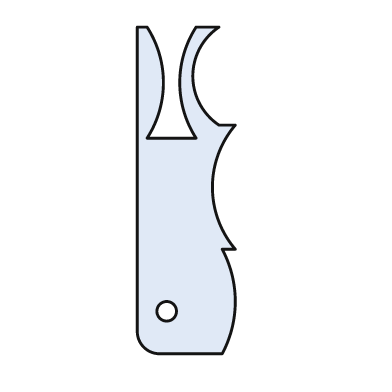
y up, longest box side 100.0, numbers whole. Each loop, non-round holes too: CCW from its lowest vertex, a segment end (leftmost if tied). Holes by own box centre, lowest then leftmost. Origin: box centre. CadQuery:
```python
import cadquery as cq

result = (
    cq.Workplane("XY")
    .moveTo(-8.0, -50.0)
    .lineTo(11.0, -50.0)
    .threePointArc((15.0, -34.0), (11.0, -18.0))
    .lineTo(15.0, -18.0)
    .threePointArc((8.0, 1.0), (15.0, 20.0))
    .lineTo(10.0, 20.0)
    .threePointArc((2.0, 35.0), (10.0, 50.0))
    .lineTo(3.0, 50.0)
    .threePointArc((-2.0, 33.0), (3.0, 16.0))
    .lineTo(-12.0, 16.0)
    .threePointArc((-7.0, 33.0), (-12.0, 50.0))
    .lineTo(-15.0, 50.0)
    .lineTo(-15.0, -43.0)
    .threePointArc((-13.0, -48.0), (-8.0, -50.0))
    .close()
    .moveTo(-6.0, -37.0)
    .circle(3.0)
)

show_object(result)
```